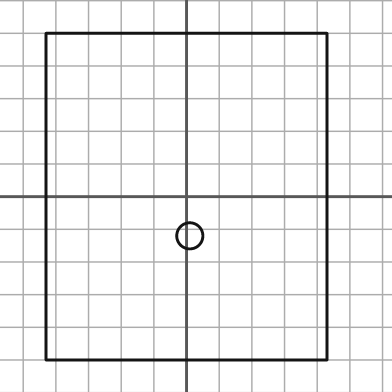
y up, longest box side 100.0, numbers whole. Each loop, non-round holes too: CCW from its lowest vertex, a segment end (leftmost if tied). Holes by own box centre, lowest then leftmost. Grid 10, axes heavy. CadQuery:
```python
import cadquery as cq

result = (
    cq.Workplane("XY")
    .moveTo(-43.0, -50.0)
    .lineTo(43.0, -50.0)
    .lineTo(43.0, 50.0)
    .lineTo(-43.0, 50.0)
    .close()
    .moveTo(1.0, -12.0)
    .circle(4.0)
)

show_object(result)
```